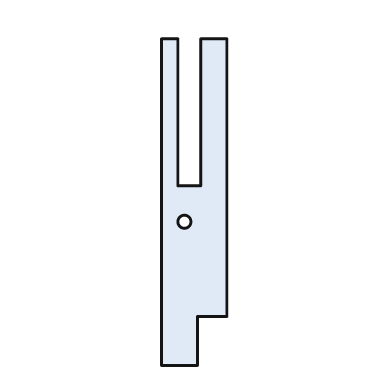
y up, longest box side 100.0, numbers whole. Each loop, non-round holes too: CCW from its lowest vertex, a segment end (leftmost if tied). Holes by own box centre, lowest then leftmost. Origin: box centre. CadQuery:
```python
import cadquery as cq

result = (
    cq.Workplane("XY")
    .moveTo(-10.0, -50.0)
    .lineTo(1.0, -50.0)
    .lineTo(1.0, -35.0)
    .lineTo(10.0, -35.0)
    .lineTo(10.0, 50.0)
    .lineTo(2.0, 50.0)
    .lineTo(2.0, 5.0)
    .lineTo(-5.0, 5.0)
    .lineTo(-5.0, 50.0)
    .lineTo(-10.0, 50.0)
    .close()
    .moveTo(-3.0, -6.0)
    .circle(2.0)
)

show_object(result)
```